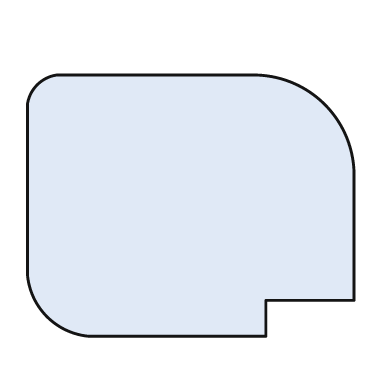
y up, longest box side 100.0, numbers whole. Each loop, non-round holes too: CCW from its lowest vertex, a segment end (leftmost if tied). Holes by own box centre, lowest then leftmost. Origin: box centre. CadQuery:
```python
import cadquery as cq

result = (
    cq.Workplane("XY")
    .moveTo(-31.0, -40.0)
    .lineTo(23.0, -40.0)
    .lineTo(23.0, -29.0)
    .lineTo(50.0, -29.0)
    .lineTo(50.0, 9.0)
    .threePointArc((41.0, 31.0), (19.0, 40.0))
    .lineTo(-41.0, 40.0)
    .threePointArc((-47.0, 37.0), (-50.0, 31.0))
    .lineTo(-50.0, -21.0)
    .threePointArc((-44.0, -34.0), (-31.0, -40.0))
    .close()
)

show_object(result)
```